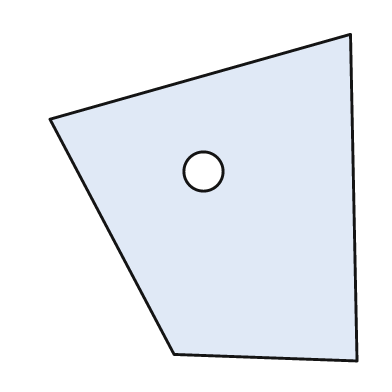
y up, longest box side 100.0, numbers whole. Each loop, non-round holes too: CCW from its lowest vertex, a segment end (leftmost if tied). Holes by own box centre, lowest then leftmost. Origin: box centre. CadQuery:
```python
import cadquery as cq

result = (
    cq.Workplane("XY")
    .moveTo(47.0, -50.0)
    .lineTo(45.0, 50.0)
    .lineTo(-47.0, 24.0)
    .lineTo(-9.0, -48.0)
    .close()
    .moveTo(0.0, 8.0)
    .circle(6.0)
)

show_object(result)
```